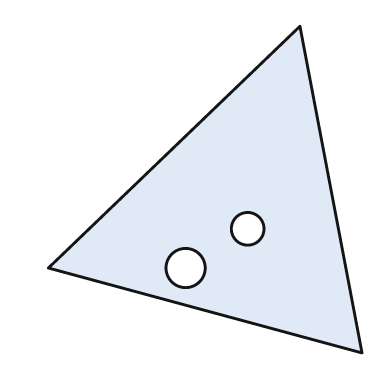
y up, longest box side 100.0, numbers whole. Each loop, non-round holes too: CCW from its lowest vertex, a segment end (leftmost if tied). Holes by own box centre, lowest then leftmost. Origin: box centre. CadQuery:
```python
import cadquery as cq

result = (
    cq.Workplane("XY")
    .moveTo(48.0, -50.0)
    .lineTo(29.0, 50.0)
    .lineTo(-48.0, -24.0)
    .close()
    .moveTo(-6.0, -24.0)
    .circle(6.0)
    .moveTo(13.0, -12.0)
    .circle(5.0)
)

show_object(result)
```